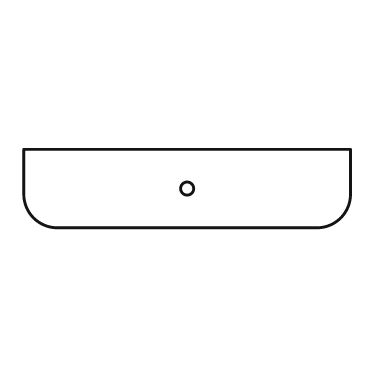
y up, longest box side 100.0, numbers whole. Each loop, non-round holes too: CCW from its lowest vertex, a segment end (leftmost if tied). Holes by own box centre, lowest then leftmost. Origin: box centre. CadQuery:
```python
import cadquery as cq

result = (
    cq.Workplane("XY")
    .moveTo(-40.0, -12.0)
    .lineTo(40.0, -12.0)
    .threePointArc((47.0, -9.0), (50.0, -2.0))
    .lineTo(50.0, 12.0)
    .lineTo(-50.0, 12.0)
    .lineTo(-50.0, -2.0)
    .threePointArc((-47.0, -9.0), (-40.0, -12.0))
    .close()
    .moveTo(0.0, 0.0)
    .circle(2.0)
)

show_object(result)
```